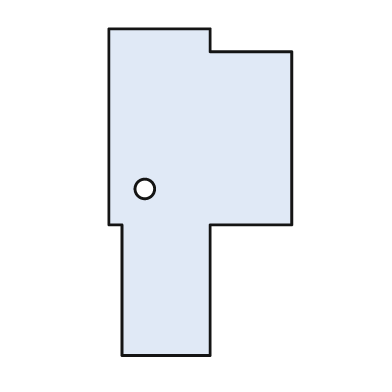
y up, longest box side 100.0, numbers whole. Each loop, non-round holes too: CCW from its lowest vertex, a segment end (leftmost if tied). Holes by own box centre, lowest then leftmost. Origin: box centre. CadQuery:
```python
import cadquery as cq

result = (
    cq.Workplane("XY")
    .moveTo(-24.0, -50.0)
    .lineTo(3.0, -50.0)
    .lineTo(3.0, -10.0)
    .lineTo(28.0, -10.0)
    .lineTo(28.0, 43.0)
    .lineTo(3.0, 43.0)
    .lineTo(3.0, 50.0)
    .lineTo(-28.0, 50.0)
    .lineTo(-28.0, -10.0)
    .lineTo(-24.0, -10.0)
    .close()
    .moveTo(-17.0, 1.0)
    .circle(3.0)
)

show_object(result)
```